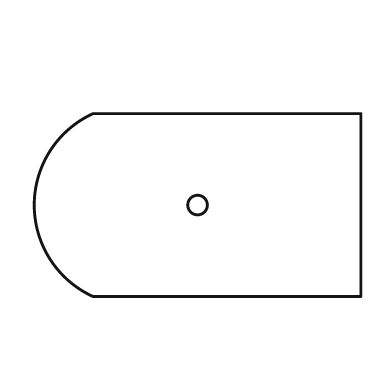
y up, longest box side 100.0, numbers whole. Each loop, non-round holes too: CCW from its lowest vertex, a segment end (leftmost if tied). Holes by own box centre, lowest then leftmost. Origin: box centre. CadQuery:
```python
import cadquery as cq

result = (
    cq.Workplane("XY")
    .moveTo(-32.0, -28.0)
    .lineTo(50.0, -28.0)
    .lineTo(50.0, 28.0)
    .lineTo(-32.0, 28.0)
    .threePointArc((-50.0, 0.0), (-32.0, -28.0))
    .close()
    .moveTo(0.0, 0.0)
    .circle(3.0)
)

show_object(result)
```